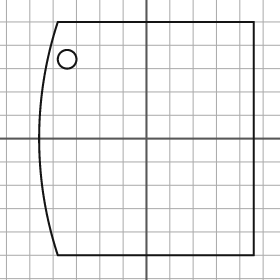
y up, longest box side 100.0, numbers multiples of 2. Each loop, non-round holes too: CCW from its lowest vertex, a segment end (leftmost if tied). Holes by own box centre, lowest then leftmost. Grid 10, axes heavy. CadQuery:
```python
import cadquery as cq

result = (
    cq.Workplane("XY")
    .moveTo(-38.0, -50.0)
    .lineTo(46.0, -50.0)
    .lineTo(46.0, 50.0)
    .lineTo(-38.0, 50.0)
    .threePointArc((-46.0, 0.0), (-38.0, -50.0))
    .close()
    .moveTo(-34.0, 34.0)
    .circle(4.0)
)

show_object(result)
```